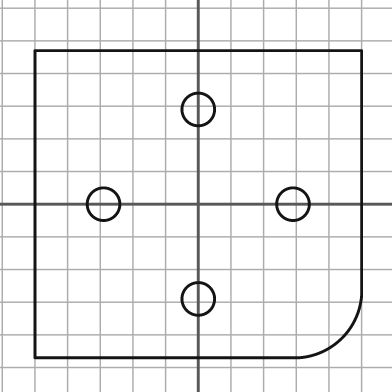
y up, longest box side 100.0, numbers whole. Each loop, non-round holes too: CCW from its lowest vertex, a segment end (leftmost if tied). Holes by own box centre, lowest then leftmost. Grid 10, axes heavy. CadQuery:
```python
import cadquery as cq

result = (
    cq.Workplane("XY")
    .moveTo(-50.0, -47.0)
    .lineTo(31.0, -47.0)
    .threePointArc((44.0, -41.0), (50.0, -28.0))
    .lineTo(50.0, 47.0)
    .lineTo(-50.0, 47.0)
    .close()
    .moveTo(0.0, -29.0)
    .circle(5.0)
    .moveTo(-29.0, 0.0)
    .circle(5.0)
    .moveTo(29.0, 0.0)
    .circle(5.0)
    .moveTo(0.0, 29.0)
    .circle(5.0)
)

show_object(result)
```